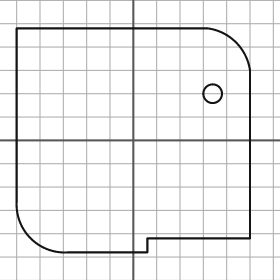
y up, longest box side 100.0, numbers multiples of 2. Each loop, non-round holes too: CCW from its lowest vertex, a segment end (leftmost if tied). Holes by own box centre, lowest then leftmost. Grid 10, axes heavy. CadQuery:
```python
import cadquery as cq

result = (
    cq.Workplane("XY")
    .moveTo(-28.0, -48.0)
    .lineTo(6.0, -48.0)
    .lineTo(6.0, -42.0)
    .lineTo(50.0, -42.0)
    .lineTo(50.0, 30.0)
    .threePointArc((44.0, 42.0), (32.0, 48.0))
    .lineTo(-50.0, 48.0)
    .lineTo(-50.0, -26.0)
    .threePointArc((-44.0, -42.0), (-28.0, -48.0))
    .close()
    .moveTo(34.0, 20.0)
    .circle(4.0)
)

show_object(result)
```